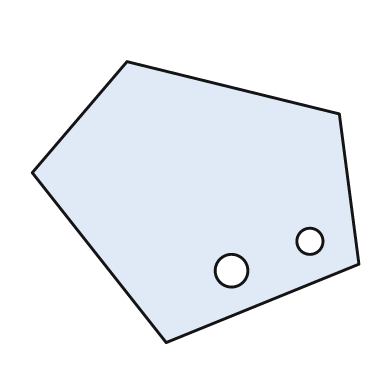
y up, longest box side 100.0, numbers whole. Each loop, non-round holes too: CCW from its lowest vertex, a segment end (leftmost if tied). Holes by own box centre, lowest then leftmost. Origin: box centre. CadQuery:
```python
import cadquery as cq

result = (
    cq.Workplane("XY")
    .moveTo(-9.0, -43.0)
    .lineTo(50.0, -19.0)
    .lineTo(44.0, 27.0)
    .lineTo(-21.0, 43.0)
    .lineTo(-50.0, 9.0)
    .close()
    .moveTo(11.0, -21.0)
    .circle(5.0)
    .moveTo(35.0, -12.0)
    .circle(4.0)
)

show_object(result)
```